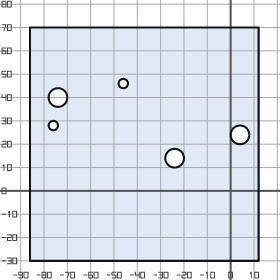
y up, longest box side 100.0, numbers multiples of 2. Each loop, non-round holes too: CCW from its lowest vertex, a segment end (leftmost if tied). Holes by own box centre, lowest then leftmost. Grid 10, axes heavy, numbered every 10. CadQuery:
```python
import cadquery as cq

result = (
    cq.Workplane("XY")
    .moveTo(-86.0, -30.0)
    .lineTo(12.0, -30.0)
    .lineTo(12.0, 70.0)
    .lineTo(-86.0, 70.0)
    .close()
    .moveTo(-24.0, 14.0)
    .circle(4.0)
    .moveTo(4.0, 24.0)
    .circle(4.0)
    .moveTo(-76.0, 28.0)
    .circle(2.0)
    .moveTo(-74.0, 40.0)
    .circle(4.0)
    .moveTo(-46.0, 46.0)
    .circle(2.0)
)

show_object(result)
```